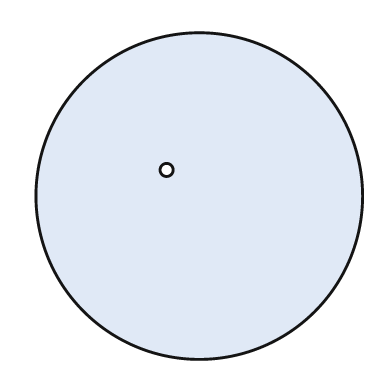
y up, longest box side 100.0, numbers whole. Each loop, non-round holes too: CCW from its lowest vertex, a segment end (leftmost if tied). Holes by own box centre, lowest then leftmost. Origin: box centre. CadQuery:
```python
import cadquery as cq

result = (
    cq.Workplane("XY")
    .moveTo(0.0, 0.0)
    .circle(50.0)
    .moveTo(-10.0, 8.0)
    .circle(2.0)
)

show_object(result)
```